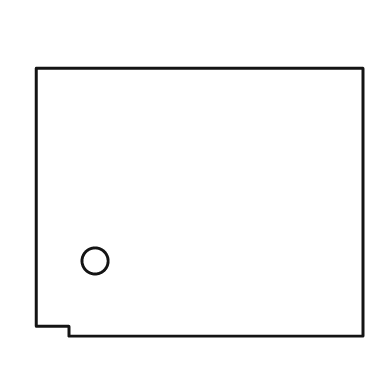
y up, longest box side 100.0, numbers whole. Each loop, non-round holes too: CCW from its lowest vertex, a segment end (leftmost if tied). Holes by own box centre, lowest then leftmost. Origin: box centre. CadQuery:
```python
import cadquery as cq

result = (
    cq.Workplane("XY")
    .moveTo(-40.0, -41.0)
    .lineTo(50.0, -41.0)
    .lineTo(50.0, 41.0)
    .lineTo(-50.0, 41.0)
    .lineTo(-50.0, -38.0)
    .lineTo(-40.0, -38.0)
    .close()
    .moveTo(-32.0, -18.0)
    .circle(4.0)
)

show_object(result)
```